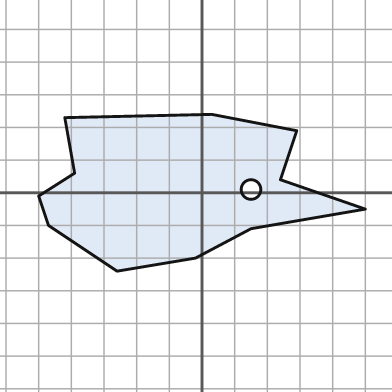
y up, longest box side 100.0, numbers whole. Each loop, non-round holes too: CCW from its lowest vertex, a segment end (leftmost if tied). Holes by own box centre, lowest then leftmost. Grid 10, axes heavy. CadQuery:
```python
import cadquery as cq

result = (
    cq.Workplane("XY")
    .moveTo(-26.0, -24.0)
    .lineTo(-2.0, -20.0)
    .lineTo(15.0, -11.0)
    .lineTo(50.0, -5.0)
    .lineTo(24.0, 4.0)
    .lineTo(29.0, 19.0)
    .lineTo(3.0, 24.0)
    .lineTo(-42.0, 23.0)
    .lineTo(-39.0, 6.0)
    .lineTo(-50.0, -1.0)
    .lineTo(-47.0, -10.0)
    .close()
    .moveTo(15.0, 1.0)
    .circle(3.0)
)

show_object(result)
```